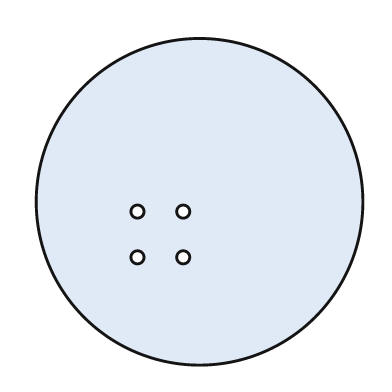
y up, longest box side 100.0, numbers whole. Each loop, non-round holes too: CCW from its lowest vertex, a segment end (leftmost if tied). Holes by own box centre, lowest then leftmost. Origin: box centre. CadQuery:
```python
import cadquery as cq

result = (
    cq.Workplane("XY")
    .moveTo(0.0, 0.0)
    .circle(50.0)
    .moveTo(-19.0, -17.0)
    .circle(2.0)
    .moveTo(-5.0, -17.0)
    .circle(2.0)
    .moveTo(-19.0, -3.0)
    .circle(2.0)
    .moveTo(-5.0, -3.0)
    .circle(2.0)
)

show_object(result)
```